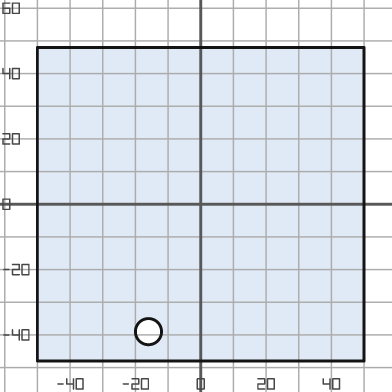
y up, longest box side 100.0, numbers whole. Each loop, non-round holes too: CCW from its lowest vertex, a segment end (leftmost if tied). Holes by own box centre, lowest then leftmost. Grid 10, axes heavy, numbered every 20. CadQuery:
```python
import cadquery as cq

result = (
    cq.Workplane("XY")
    .moveTo(-50.0, -48.0)
    .lineTo(50.0, -48.0)
    .lineTo(50.0, 48.0)
    .lineTo(-50.0, 48.0)
    .close()
    .moveTo(-16.0, -39.0)
    .circle(4.0)
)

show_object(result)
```